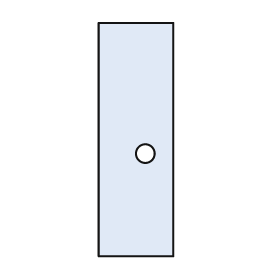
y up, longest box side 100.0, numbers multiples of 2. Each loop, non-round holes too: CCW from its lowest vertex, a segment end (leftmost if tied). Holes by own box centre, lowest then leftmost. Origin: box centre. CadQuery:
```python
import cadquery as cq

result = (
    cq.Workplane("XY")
    .moveTo(-16.0, -50.0)
    .lineTo(16.0, -50.0)
    .lineTo(16.0, 50.0)
    .lineTo(-16.0, 50.0)
    .close()
    .moveTo(4.0, -6.0)
    .circle(4.0)
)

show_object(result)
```